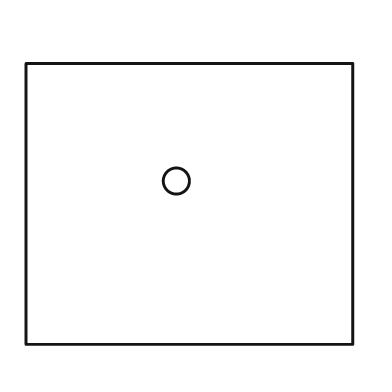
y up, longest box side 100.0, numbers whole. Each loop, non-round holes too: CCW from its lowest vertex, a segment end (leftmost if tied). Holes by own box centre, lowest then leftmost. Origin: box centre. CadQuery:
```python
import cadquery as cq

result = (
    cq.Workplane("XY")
    .moveTo(-50.0, -43.0)
    .lineTo(50.0, -43.0)
    .lineTo(50.0, 43.0)
    .lineTo(-50.0, 43.0)
    .close()
    .moveTo(-4.0, 7.0)
    .circle(4.0)
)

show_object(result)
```